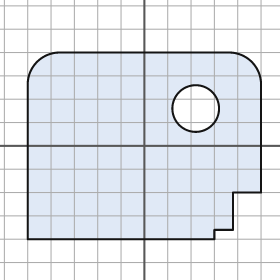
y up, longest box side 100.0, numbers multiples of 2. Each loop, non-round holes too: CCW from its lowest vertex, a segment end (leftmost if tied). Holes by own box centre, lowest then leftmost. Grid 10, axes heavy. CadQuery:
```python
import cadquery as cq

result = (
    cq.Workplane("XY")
    .moveTo(-50.0, -40.0)
    .lineTo(30.0, -40.0)
    .lineTo(30.0, -36.0)
    .lineTo(38.0, -36.0)
    .lineTo(38.0, -20.0)
    .lineTo(50.0, -20.0)
    .lineTo(50.0, 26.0)
    .threePointArc((46.0, 36.0), (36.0, 40.0))
    .lineTo(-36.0, 40.0)
    .threePointArc((-46.0, 36.0), (-50.0, 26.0))
    .close()
    .moveTo(22.0, 16.0)
    .circle(10.0)
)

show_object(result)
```